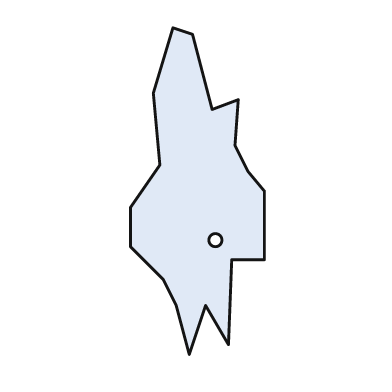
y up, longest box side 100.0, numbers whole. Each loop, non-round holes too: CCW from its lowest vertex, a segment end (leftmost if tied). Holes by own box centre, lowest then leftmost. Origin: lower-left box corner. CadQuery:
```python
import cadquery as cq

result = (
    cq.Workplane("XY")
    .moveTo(18.0, 0.0)
    .lineTo(23.0, 15.0)
    .lineTo(30.0, 3.0)
    .lineTo(31.0, 29.0)
    .lineTo(41.0, 29.0)
    .lineTo(41.0, 50.0)
    .lineTo(36.0, 56.0)
    .lineTo(32.0, 64.0)
    .lineTo(33.0, 78.0)
    .lineTo(25.0, 75.0)
    .lineTo(19.0, 98.0)
    .lineTo(13.0, 100.0)
    .lineTo(7.0, 80.0)
    .lineTo(9.0, 58.0)
    .lineTo(0.0, 45.0)
    .lineTo(0.0, 33.0)
    .lineTo(10.0, 23.0)
    .lineTo(14.0, 15.0)
    .close()
    .moveTo(26.0, 35.0)
    .circle(2.0)
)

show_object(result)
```